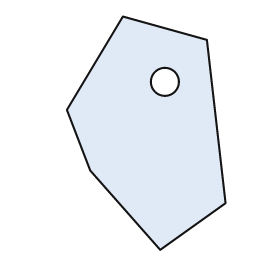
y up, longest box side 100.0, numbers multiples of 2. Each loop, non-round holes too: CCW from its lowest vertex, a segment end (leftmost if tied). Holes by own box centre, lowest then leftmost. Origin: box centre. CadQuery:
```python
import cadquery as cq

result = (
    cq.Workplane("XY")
    .moveTo(6.0, -50.0)
    .lineTo(34.0, -30.0)
    .lineTo(26.0, 40.0)
    .lineTo(-10.0, 50.0)
    .lineTo(-34.0, 10.0)
    .lineTo(-24.0, -16.0)
    .close()
    .moveTo(8.0, 22.0)
    .circle(6.0)
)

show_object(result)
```